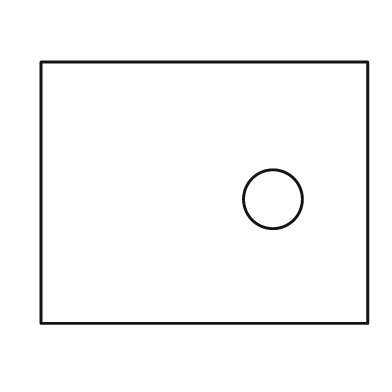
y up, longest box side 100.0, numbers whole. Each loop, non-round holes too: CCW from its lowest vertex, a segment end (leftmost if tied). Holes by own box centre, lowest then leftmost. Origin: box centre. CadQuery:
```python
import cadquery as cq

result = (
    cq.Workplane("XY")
    .moveTo(-50.0, -40.0)
    .lineTo(50.0, -40.0)
    .lineTo(50.0, 40.0)
    .lineTo(-50.0, 40.0)
    .close()
    .moveTo(21.0, -2.0)
    .circle(9.0)
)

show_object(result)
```